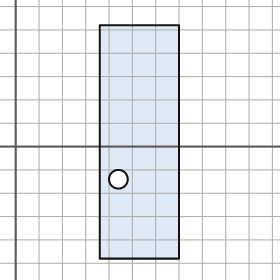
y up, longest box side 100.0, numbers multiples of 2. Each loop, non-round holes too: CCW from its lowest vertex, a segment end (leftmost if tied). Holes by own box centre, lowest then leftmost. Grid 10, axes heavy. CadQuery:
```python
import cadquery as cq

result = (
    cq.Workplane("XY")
    .moveTo(36.0, -48.0)
    .lineTo(70.0, -48.0)
    .lineTo(70.0, 52.0)
    .lineTo(36.0, 52.0)
    .close()
    .moveTo(44.0, -14.0)
    .circle(4.0)
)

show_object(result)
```